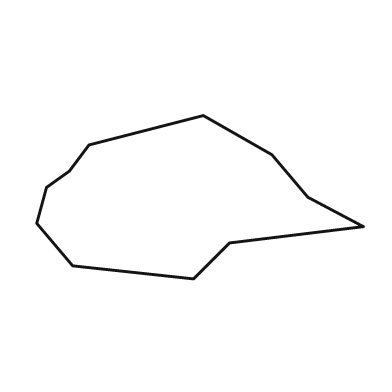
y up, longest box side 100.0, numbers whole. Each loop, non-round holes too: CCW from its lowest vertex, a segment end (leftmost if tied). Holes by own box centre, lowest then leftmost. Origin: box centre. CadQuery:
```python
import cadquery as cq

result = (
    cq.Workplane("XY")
    .moveTo(-2.0, -25.0)
    .lineTo(9.0, -14.0)
    .lineTo(50.0, -9.0)
    .lineTo(33.0, 0.0)
    .lineTo(22.0, 13.0)
    .lineTo(1.0, 25.0)
    .lineTo(-34.0, 16.0)
    .lineTo(-40.0, 8.0)
    .lineTo(-47.0, 3.0)
    .lineTo(-50.0, -8.0)
    .lineTo(-39.0, -21.0)
    .close()
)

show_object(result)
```